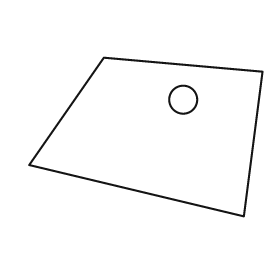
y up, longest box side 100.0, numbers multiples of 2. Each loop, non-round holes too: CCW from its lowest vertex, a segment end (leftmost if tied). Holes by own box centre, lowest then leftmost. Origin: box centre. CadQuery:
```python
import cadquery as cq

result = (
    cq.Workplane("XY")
    .moveTo(42.0, -34.0)
    .lineTo(50.0, 28.0)
    .lineTo(-18.0, 34.0)
    .lineTo(-50.0, -12.0)
    .close()
    .moveTo(16.0, 16.0)
    .circle(6.0)
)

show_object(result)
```